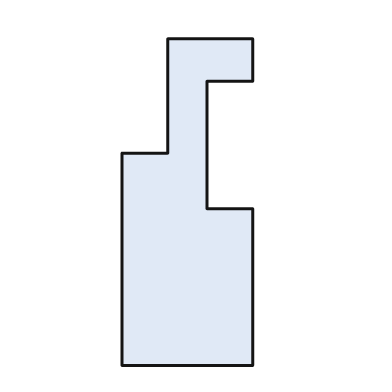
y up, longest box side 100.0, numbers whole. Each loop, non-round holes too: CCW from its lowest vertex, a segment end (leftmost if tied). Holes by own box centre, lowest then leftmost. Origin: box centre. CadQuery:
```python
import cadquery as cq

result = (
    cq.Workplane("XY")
    .moveTo(-20.0, -50.0)
    .lineTo(20.0, -50.0)
    .lineTo(20.0, -2.0)
    .lineTo(6.0, -2.0)
    .lineTo(6.0, 37.0)
    .lineTo(20.0, 37.0)
    .lineTo(20.0, 50.0)
    .lineTo(-6.0, 50.0)
    .lineTo(-6.0, 15.0)
    .lineTo(-20.0, 15.0)
    .close()
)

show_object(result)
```